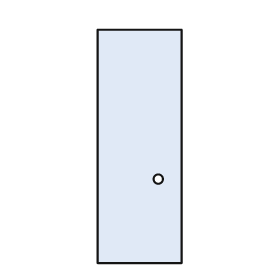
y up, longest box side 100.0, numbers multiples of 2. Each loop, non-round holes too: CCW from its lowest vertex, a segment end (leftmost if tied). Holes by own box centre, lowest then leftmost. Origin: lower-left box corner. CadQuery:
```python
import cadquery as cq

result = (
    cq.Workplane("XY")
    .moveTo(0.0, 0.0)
    .lineTo(36.0, 0.0)
    .lineTo(36.0, 100.0)
    .lineTo(0.0, 100.0)
    .close()
    .moveTo(26.0, 36.0)
    .circle(2.0)
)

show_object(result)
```